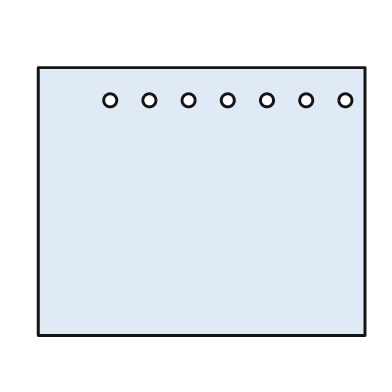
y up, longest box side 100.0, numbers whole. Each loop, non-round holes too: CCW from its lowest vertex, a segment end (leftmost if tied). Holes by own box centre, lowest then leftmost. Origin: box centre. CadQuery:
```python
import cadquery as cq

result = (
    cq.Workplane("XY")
    .moveTo(-50.0, -41.0)
    .lineTo(50.0, -41.0)
    .lineTo(50.0, 41.0)
    .lineTo(-50.0, 41.0)
    .close()
    .moveTo(-28.0, 31.0)
    .circle(2.0)
    .moveTo(-16.0, 31.0)
    .circle(2.0)
    .moveTo(-4.0, 31.0)
    .circle(2.0)
    .moveTo(8.0, 31.0)
    .circle(2.0)
    .moveTo(20.0, 31.0)
    .circle(2.0)
    .moveTo(32.0, 31.0)
    .circle(2.0)
    .moveTo(44.0, 31.0)
    .circle(2.0)
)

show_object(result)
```